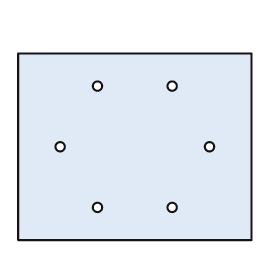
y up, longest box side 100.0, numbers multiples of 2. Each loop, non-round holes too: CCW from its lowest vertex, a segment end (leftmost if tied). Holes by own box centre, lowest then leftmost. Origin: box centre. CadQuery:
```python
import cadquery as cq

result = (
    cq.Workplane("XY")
    .moveTo(-50.0, -40.0)
    .lineTo(50.0, -40.0)
    .lineTo(50.0, 40.0)
    .lineTo(-50.0, 40.0)
    .close()
    .moveTo(-16.0, -26.0)
    .circle(2.0)
    .moveTo(16.0, -26.0)
    .circle(2.0)
    .moveTo(-32.0, 0.0)
    .circle(2.0)
    .moveTo(32.0, 0.0)
    .circle(2.0)
    .moveTo(-16.0, 26.0)
    .circle(2.0)
    .moveTo(16.0, 26.0)
    .circle(2.0)
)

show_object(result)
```